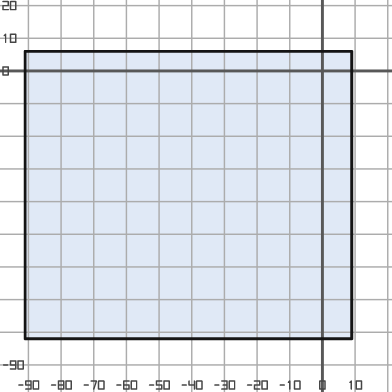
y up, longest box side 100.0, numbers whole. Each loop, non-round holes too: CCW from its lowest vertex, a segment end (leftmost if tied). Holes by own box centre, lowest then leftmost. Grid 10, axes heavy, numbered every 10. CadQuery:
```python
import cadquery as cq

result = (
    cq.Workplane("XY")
    .moveTo(-91.0, -82.0)
    .lineTo(9.0, -82.0)
    .lineTo(9.0, 6.0)
    .lineTo(-91.0, 6.0)
    .close()
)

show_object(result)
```